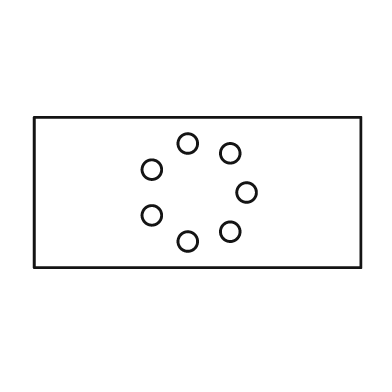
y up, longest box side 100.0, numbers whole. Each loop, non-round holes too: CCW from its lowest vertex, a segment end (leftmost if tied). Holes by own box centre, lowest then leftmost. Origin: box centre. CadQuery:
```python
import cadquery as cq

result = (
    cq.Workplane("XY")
    .moveTo(-50.0, -23.0)
    .lineTo(50.0, -23.0)
    .lineTo(50.0, 23.0)
    .lineTo(-50.0, 23.0)
    .close()
    .moveTo(-3.0, -15.0)
    .circle(3.0)
    .moveTo(10.0, -12.0)
    .circle(3.0)
    .moveTo(-14.0, -7.0)
    .circle(3.0)
    .moveTo(15.0, 0.0)
    .circle(3.0)
    .moveTo(-14.0, 7.0)
    .circle(3.0)
    .moveTo(10.0, 12.0)
    .circle(3.0)
    .moveTo(-3.0, 15.0)
    .circle(3.0)
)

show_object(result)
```